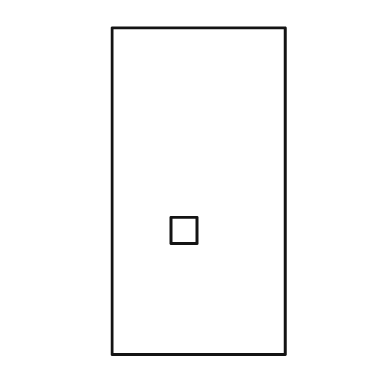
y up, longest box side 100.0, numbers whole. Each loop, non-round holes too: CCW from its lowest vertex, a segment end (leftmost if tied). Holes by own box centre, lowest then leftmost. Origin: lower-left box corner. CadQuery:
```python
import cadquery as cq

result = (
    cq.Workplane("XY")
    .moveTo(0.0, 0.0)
    .lineTo(53.0, 0.0)
    .lineTo(53.0, 100.0)
    .lineTo(0.0, 100.0)
    .close()
    .moveTo(18.0, 34.0)
    .lineTo(26.0, 34.0)
    .lineTo(26.0, 42.0)
    .lineTo(18.0, 42.0)
    .close()
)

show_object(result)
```